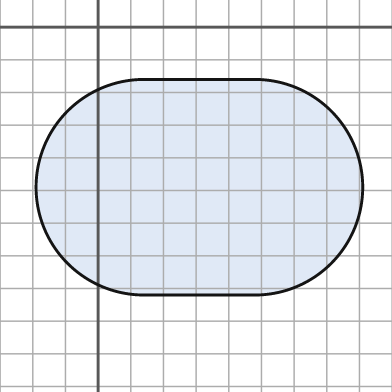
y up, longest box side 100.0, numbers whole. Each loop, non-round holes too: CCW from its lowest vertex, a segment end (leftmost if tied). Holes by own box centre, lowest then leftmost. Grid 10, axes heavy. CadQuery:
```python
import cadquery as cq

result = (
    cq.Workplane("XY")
    .moveTo(14.0, -82.0)
    .lineTo(48.0, -82.0)
    .threePointArc((81.0, -49.0), (48.0, -16.0))
    .lineTo(14.0, -16.0)
    .threePointArc((-19.0, -49.0), (14.0, -82.0))
    .close()
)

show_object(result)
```